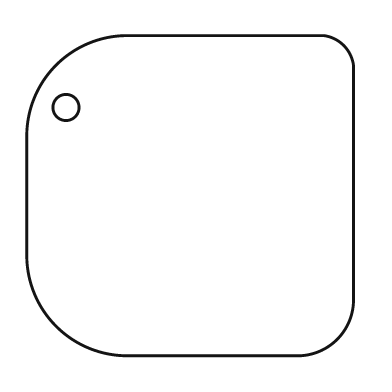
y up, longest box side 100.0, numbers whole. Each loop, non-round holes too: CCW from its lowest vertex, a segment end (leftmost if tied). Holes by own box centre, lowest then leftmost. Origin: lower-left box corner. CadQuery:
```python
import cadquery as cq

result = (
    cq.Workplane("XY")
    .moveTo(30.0, 0.0)
    .lineTo(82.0, 0.0)
    .threePointArc((95.0, 5.0), (100.0, 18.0))
    .lineTo(100.0, 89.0)
    .threePointArc((97.0, 95.0), (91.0, 98.0))
    .lineTo(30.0, 98.0)
    .threePointArc((9.0, 89.0), (0.0, 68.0))
    .lineTo(0.0, 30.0)
    .threePointArc((9.0, 9.0), (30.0, 0.0))
    .close()
    .moveTo(12.0, 76.0)
    .circle(4.0)
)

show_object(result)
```